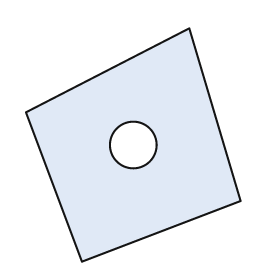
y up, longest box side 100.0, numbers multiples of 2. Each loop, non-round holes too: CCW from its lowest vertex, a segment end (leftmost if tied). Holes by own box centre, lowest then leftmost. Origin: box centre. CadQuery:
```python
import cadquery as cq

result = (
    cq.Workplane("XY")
    .moveTo(-22.0, -50.0)
    .lineTo(46.0, -24.0)
    .lineTo(24.0, 50.0)
    .lineTo(-46.0, 14.0)
    .close()
    .moveTo(0.0, 0.0)
    .circle(10.0)
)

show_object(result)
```